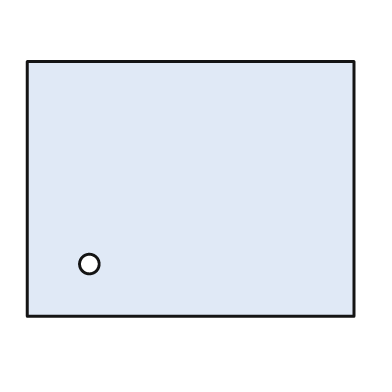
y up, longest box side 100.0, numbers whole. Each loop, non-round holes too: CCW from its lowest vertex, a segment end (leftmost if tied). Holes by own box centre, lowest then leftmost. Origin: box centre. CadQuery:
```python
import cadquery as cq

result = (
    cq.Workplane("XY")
    .moveTo(-50.0, -39.0)
    .lineTo(50.0, -39.0)
    .lineTo(50.0, 39.0)
    .lineTo(-50.0, 39.0)
    .close()
    .moveTo(-31.0, -23.0)
    .circle(3.0)
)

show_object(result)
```